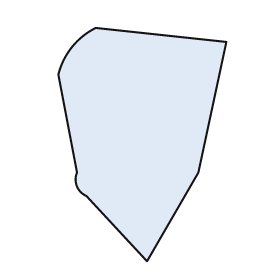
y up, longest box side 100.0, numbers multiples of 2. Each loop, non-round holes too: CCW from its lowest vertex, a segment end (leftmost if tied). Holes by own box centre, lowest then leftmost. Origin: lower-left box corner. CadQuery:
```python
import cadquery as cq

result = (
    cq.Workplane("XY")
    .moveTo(38.0, 0.0)
    .lineTo(60.0, 38.0)
    .lineTo(72.0, 94.0)
    .lineTo(16.0, 100.0)
    .threePointArc((6.0, 92.0), (0.0, 80.0))
    .lineTo(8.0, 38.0)
    .threePointArc((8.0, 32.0), (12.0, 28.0))
    .close()
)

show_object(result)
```